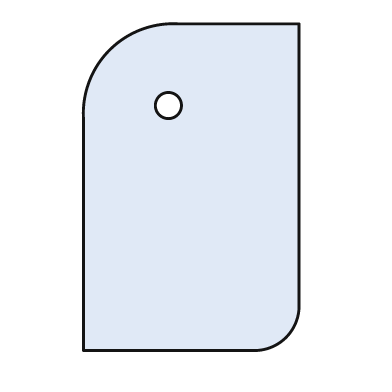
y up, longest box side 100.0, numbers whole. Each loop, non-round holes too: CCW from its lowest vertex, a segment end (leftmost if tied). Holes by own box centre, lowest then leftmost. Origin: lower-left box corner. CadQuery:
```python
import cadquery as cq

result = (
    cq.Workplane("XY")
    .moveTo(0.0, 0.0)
    .lineTo(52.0, 0.0)
    .threePointArc((62.0, 4.0), (66.0, 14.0))
    .lineTo(66.0, 100.0)
    .lineTo(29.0, 100.0)
    .threePointArc((8.0, 92.0), (0.0, 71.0))
    .close()
    .moveTo(26.0, 75.0)
    .circle(4.0)
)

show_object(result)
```